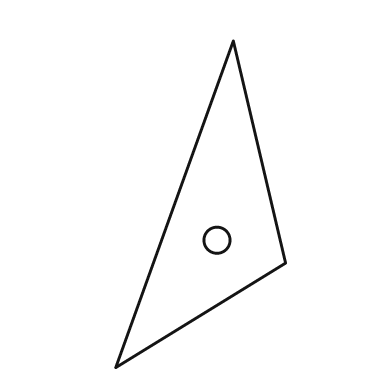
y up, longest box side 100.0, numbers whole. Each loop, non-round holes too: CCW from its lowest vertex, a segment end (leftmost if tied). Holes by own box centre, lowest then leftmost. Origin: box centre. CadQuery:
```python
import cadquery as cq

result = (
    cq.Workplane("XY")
    .moveTo(-26.0, -50.0)
    .lineTo(26.0, -18.0)
    .lineTo(10.0, 50.0)
    .close()
    .moveTo(5.0, -11.0)
    .circle(4.0)
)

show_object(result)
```